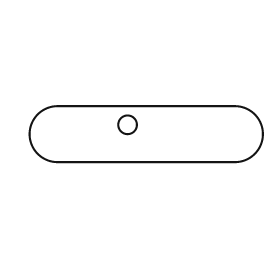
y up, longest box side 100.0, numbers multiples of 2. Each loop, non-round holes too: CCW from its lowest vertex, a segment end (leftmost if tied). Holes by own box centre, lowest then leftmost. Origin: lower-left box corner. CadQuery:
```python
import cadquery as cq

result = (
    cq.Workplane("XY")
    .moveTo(12.0, 0.0)
    .lineTo(88.0, 0.0)
    .threePointArc((100.0, 12.0), (88.0, 24.0))
    .lineTo(12.0, 24.0)
    .threePointArc((0.0, 12.0), (12.0, 0.0))
    .close()
    .moveTo(42.0, 16.0)
    .circle(4.0)
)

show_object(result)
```